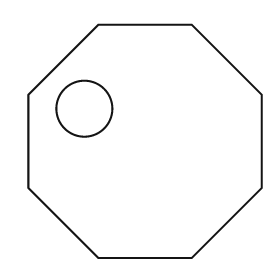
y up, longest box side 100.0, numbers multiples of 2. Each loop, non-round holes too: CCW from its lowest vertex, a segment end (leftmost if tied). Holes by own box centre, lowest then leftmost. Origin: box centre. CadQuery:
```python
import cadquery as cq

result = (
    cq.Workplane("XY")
    .moveTo(-20.0, -50.0)
    .lineTo(20.0, -50.0)
    .lineTo(50.0, -20.0)
    .lineTo(50.0, 20.0)
    .lineTo(20.0, 50.0)
    .lineTo(-20.0, 50.0)
    .lineTo(-50.0, 20.0)
    .lineTo(-50.0, -20.0)
    .close()
    .moveTo(-26.0, 14.0)
    .circle(12.0)
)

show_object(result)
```